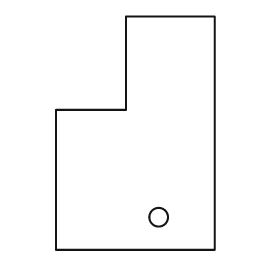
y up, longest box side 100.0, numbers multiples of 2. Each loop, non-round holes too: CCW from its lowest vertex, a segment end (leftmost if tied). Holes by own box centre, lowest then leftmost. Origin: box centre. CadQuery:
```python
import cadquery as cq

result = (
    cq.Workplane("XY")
    .moveTo(-34.0, -50.0)
    .lineTo(34.0, -50.0)
    .lineTo(34.0, 50.0)
    .lineTo(-4.0, 50.0)
    .lineTo(-4.0, 10.0)
    .lineTo(-34.0, 10.0)
    .close()
    .moveTo(10.0, -36.0)
    .circle(4.0)
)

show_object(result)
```